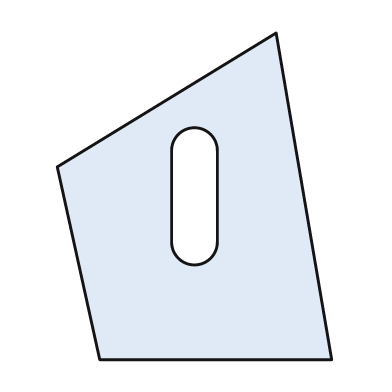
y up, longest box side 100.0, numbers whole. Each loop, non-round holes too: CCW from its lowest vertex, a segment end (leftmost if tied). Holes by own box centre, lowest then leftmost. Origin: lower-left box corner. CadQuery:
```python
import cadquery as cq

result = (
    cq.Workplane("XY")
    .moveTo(13.0, 0.0)
    .lineTo(84.0, 0.0)
    .lineTo(67.0, 100.0)
    .lineTo(0.0, 59.0)
    .close()
    .moveTo(35.0, 36.0)
    .threePointArc((42.0, 29.0), (49.0, 36.0))
    .lineTo(49.0, 64.0)
    .threePointArc((42.0, 71.0), (35.0, 64.0))
    .close()
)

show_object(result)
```